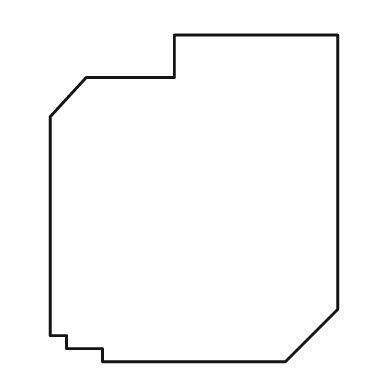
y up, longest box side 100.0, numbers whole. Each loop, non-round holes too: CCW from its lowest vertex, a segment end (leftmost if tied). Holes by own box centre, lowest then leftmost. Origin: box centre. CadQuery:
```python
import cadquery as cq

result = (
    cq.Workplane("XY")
    .moveTo(-28.0, -50.0)
    .lineTo(28.0, -50.0)
    .lineTo(44.0, -34.0)
    .lineTo(44.0, 50.0)
    .lineTo(-6.0, 50.0)
    .lineTo(-6.0, 37.0)
    .lineTo(-33.0, 37.0)
    .lineTo(-44.0, 25.0)
    .lineTo(-44.0, -42.0)
    .lineTo(-39.0, -42.0)
    .lineTo(-39.0, -46.0)
    .lineTo(-28.0, -46.0)
    .close()
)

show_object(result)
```